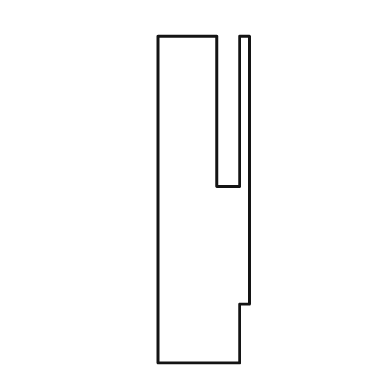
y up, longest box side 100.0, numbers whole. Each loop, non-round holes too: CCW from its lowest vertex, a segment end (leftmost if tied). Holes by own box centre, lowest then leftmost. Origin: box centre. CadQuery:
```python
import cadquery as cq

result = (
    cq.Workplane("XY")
    .moveTo(-14.0, -50.0)
    .lineTo(11.0, -50.0)
    .lineTo(11.0, -32.0)
    .lineTo(14.0, -32.0)
    .lineTo(14.0, 50.0)
    .lineTo(11.0, 50.0)
    .lineTo(11.0, 4.0)
    .lineTo(4.0, 4.0)
    .lineTo(4.0, 50.0)
    .lineTo(-14.0, 50.0)
    .close()
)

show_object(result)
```